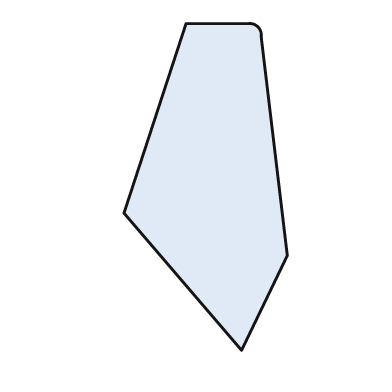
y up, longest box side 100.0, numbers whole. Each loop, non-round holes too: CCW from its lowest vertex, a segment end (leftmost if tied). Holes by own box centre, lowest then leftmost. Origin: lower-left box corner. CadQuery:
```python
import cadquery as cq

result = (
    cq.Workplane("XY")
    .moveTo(36.0, 0.0)
    .lineTo(50.0, 29.0)
    .lineTo(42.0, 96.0)
    .threePointArc((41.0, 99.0), (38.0, 100.0))
    .lineTo(19.0, 100.0)
    .lineTo(0.0, 42.0)
    .close()
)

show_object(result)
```